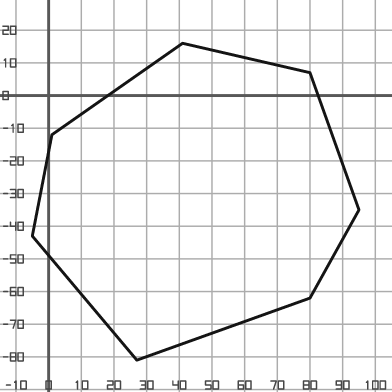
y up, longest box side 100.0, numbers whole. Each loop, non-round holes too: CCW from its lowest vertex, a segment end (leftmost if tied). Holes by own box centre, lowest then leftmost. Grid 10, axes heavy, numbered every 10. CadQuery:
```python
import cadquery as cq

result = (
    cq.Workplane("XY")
    .moveTo(27.0, -81.0)
    .lineTo(80.0, -62.0)
    .lineTo(95.0, -35.0)
    .lineTo(80.0, 7.0)
    .lineTo(41.0, 16.0)
    .lineTo(1.0, -12.0)
    .lineTo(-5.0, -43.0)
    .close()
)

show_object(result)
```